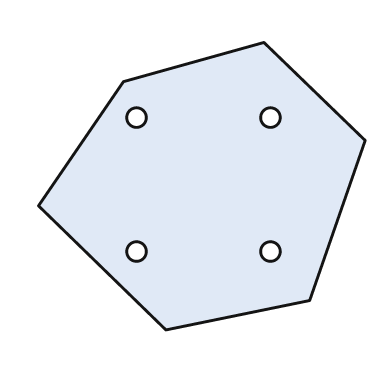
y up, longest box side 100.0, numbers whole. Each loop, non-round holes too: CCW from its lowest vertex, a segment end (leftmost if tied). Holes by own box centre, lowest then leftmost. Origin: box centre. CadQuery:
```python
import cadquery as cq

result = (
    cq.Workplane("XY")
    .moveTo(-11.0, -44.0)
    .lineTo(33.0, -35.0)
    .lineTo(50.0, 14.0)
    .lineTo(19.0, 44.0)
    .lineTo(-24.0, 32.0)
    .lineTo(-50.0, -6.0)
    .close()
    .moveTo(-20.0, -20.0)
    .circle(3.0)
    .moveTo(21.0, -20.0)
    .circle(3.0)
    .moveTo(-20.0, 21.0)
    .circle(3.0)
    .moveTo(21.0, 21.0)
    .circle(3.0)
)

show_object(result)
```